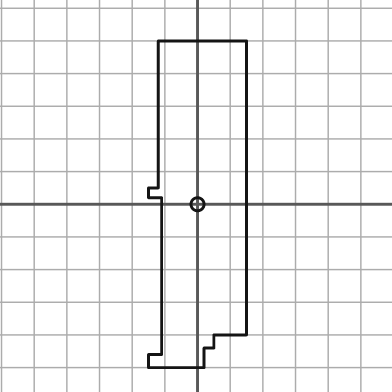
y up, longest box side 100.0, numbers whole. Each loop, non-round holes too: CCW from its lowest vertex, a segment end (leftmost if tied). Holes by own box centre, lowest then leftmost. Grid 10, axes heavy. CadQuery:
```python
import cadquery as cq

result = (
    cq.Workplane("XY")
    .moveTo(-15.0, -50.0)
    .lineTo(2.0, -50.0)
    .lineTo(2.0, -44.0)
    .lineTo(5.0, -44.0)
    .lineTo(5.0, -40.0)
    .lineTo(15.0, -40.0)
    .lineTo(15.0, 50.0)
    .lineTo(-12.0, 50.0)
    .lineTo(-12.0, 5.0)
    .lineTo(-15.0, 5.0)
    .lineTo(-15.0, 2.0)
    .lineTo(-11.0, 2.0)
    .lineTo(-11.0, -46.0)
    .lineTo(-15.0, -46.0)
    .close()
    .moveTo(0.0, 0.0)
    .circle(2.0)
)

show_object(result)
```